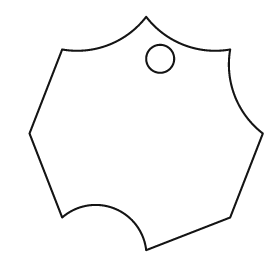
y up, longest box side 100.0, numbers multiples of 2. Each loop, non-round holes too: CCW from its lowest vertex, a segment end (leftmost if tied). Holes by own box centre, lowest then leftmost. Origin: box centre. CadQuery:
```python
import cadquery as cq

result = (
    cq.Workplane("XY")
    .moveTo(0.0, -50.0)
    .lineTo(36.0, -36.0)
    .lineTo(50.0, 0.0)
    .threePointArc((38.0, 16.0), (36.0, 36.0))
    .threePointArc((16.0, 38.0), (0.0, 50.0))
    .threePointArc((-16.0, 38.0), (-36.0, 36.0))
    .lineTo(-50.0, 0.0)
    .lineTo(-36.0, -36.0)
    .threePointArc((-14.0, -32.0), (0.0, -50.0))
    .close()
    .moveTo(6.0, 32.0)
    .circle(6.0)
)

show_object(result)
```